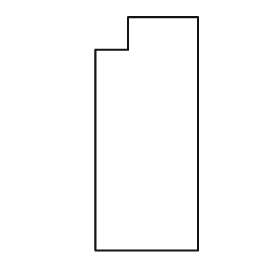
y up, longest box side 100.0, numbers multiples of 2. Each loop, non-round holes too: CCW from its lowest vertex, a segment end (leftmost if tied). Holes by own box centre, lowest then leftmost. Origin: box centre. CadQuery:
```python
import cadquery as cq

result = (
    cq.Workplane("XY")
    .moveTo(-22.0, -50.0)
    .lineTo(22.0, -50.0)
    .lineTo(22.0, 50.0)
    .lineTo(-8.0, 50.0)
    .lineTo(-8.0, 36.0)
    .lineTo(-22.0, 36.0)
    .close()
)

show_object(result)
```